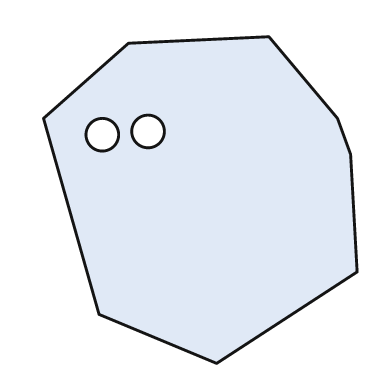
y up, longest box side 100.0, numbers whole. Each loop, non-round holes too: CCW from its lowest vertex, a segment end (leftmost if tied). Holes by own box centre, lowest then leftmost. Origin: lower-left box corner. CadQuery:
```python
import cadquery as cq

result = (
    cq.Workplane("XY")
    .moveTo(53.0, 0.0)
    .lineTo(96.0, 28.0)
    .lineTo(94.0, 64.0)
    .lineTo(90.0, 75.0)
    .lineTo(69.0, 100.0)
    .lineTo(26.0, 98.0)
    .lineTo(0.0, 75.0)
    .lineTo(17.0, 15.0)
    .close()
    .moveTo(18.0, 70.0)
    .circle(5.0)
    .moveTo(32.0, 71.0)
    .circle(5.0)
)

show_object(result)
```